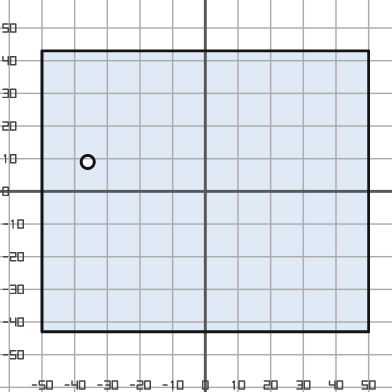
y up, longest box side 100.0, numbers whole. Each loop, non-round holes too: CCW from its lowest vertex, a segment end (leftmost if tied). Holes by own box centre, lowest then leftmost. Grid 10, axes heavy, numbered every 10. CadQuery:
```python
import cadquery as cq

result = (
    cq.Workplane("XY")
    .moveTo(-50.0, -43.0)
    .lineTo(50.0, -43.0)
    .lineTo(50.0, 43.0)
    .lineTo(-50.0, 43.0)
    .close()
    .moveTo(-36.0, 9.0)
    .circle(2.0)
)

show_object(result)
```